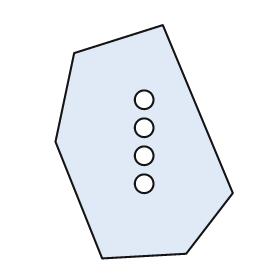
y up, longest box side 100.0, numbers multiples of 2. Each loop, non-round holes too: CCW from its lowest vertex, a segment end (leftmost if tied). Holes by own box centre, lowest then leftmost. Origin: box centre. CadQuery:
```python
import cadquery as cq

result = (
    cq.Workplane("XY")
    .moveTo(-18.0, -50.0)
    .lineTo(18.0, -48.0)
    .lineTo(38.0, -22.0)
    .lineTo(8.0, 50.0)
    .lineTo(-30.0, 38.0)
    .lineTo(-38.0, 0.0)
    .close()
    .moveTo(0.0, -18.0)
    .circle(4.0)
    .moveTo(0.0, -6.0)
    .circle(4.0)
    .moveTo(0.0, 6.0)
    .circle(4.0)
    .moveTo(0.0, 18.0)
    .circle(4.0)
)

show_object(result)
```